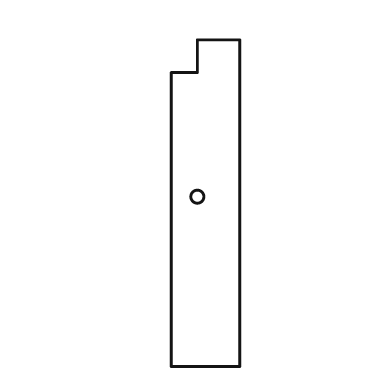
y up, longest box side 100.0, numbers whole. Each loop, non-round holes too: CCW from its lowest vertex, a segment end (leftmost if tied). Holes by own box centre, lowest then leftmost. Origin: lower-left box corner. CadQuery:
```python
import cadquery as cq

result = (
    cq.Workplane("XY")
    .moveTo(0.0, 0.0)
    .lineTo(21.0, 0.0)
    .lineTo(21.0, 100.0)
    .lineTo(8.0, 100.0)
    .lineTo(8.0, 90.0)
    .lineTo(0.0, 90.0)
    .close()
    .moveTo(8.0, 52.0)
    .circle(2.0)
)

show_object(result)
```